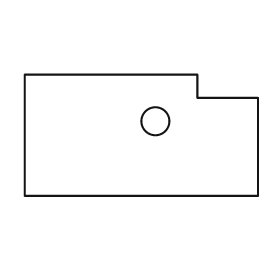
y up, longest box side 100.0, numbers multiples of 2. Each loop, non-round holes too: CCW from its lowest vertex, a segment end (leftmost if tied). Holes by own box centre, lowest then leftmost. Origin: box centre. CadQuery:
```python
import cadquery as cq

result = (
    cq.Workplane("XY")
    .moveTo(-50.0, -26.0)
    .lineTo(50.0, -26.0)
    .lineTo(50.0, 16.0)
    .lineTo(24.0, 16.0)
    .lineTo(24.0, 26.0)
    .lineTo(-50.0, 26.0)
    .close()
    .moveTo(6.0, 6.0)
    .circle(6.0)
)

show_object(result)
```